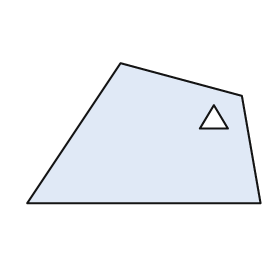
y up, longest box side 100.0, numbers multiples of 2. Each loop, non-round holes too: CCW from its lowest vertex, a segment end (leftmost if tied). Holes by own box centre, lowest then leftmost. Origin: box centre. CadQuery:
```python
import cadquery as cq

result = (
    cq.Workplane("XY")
    .moveTo(-50.0, -30.0)
    .lineTo(50.0, -30.0)
    .lineTo(42.0, 16.0)
    .lineTo(-10.0, 30.0)
    .close()
    .moveTo(24.0, 2.0)
    .lineTo(36.0, 2.0)
    .lineTo(30.0, 12.0)
    .close()
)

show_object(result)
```